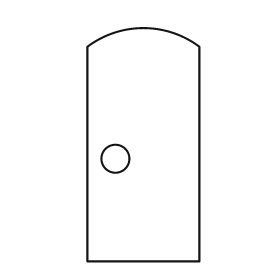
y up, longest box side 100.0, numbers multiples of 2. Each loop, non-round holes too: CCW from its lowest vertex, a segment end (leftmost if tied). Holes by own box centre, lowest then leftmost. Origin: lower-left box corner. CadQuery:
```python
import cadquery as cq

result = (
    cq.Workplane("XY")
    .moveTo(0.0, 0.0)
    .lineTo(48.0, 0.0)
    .lineTo(48.0, 92.0)
    .threePointArc((24.0, 100.0), (0.0, 92.0))
    .close()
    .moveTo(12.0, 44.0)
    .circle(6.0)
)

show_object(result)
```